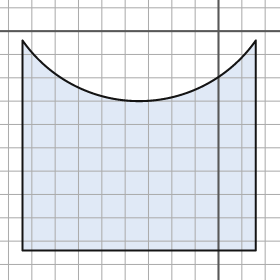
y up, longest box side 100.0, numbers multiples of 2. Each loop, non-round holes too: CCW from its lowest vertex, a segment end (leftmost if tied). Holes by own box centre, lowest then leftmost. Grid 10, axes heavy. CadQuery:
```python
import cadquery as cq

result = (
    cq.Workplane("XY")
    .moveTo(-84.0, -94.0)
    .lineTo(16.0, -94.0)
    .lineTo(16.0, -4.0)
    .threePointArc((-34.0, -30.0), (-84.0, -4.0))
    .close()
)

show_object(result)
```